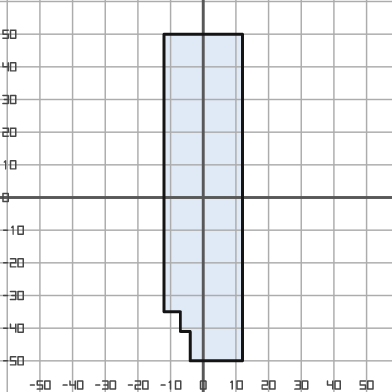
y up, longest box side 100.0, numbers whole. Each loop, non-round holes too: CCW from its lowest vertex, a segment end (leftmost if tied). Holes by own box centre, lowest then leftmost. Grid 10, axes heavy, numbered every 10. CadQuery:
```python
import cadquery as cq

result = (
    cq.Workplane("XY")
    .moveTo(-4.0, -50.0)
    .lineTo(12.0, -50.0)
    .lineTo(12.0, 50.0)
    .lineTo(-12.0, 50.0)
    .lineTo(-12.0, -35.0)
    .lineTo(-7.0, -35.0)
    .lineTo(-7.0, -41.0)
    .lineTo(-4.0, -41.0)
    .close()
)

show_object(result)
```